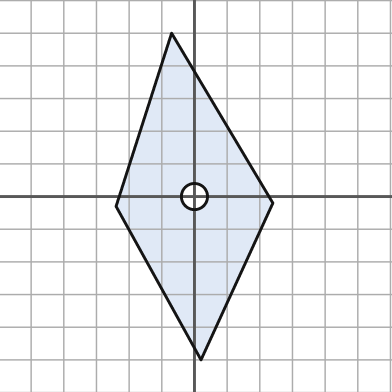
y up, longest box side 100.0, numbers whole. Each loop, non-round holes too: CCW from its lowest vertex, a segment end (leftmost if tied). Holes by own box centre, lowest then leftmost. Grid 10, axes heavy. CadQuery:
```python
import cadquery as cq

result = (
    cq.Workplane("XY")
    .moveTo(2.0, -50.0)
    .lineTo(24.0, -2.0)
    .lineTo(-7.0, 50.0)
    .lineTo(-24.0, -3.0)
    .close()
    .moveTo(0.0, 0.0)
    .circle(4.0)
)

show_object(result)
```